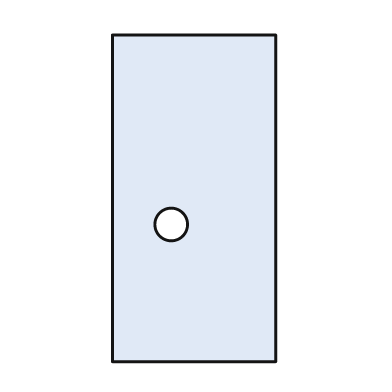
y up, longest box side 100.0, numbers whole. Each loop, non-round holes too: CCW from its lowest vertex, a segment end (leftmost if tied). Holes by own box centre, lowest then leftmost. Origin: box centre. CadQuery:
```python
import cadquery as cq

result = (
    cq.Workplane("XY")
    .moveTo(-25.0, -50.0)
    .lineTo(25.0, -50.0)
    .lineTo(25.0, 50.0)
    .lineTo(-25.0, 50.0)
    .close()
    .moveTo(-7.0, -8.0)
    .circle(5.0)
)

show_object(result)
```